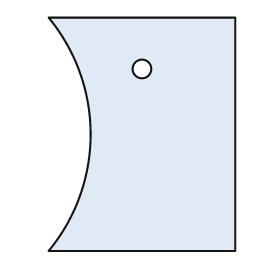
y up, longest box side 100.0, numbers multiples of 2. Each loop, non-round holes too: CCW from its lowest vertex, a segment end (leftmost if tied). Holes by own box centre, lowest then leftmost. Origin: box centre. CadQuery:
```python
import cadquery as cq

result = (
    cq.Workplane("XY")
    .moveTo(-40.0, -50.0)
    .lineTo(40.0, -50.0)
    .lineTo(40.0, 50.0)
    .lineTo(-40.0, 50.0)
    .threePointArc((-22.0, 0.0), (-40.0, -50.0))
    .close()
    .moveTo(0.0, 28.0)
    .circle(4.0)
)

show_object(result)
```